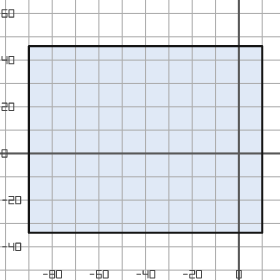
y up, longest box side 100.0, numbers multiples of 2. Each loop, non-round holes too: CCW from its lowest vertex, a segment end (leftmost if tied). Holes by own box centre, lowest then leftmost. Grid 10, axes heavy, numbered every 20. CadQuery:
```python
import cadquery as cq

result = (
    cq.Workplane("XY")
    .moveTo(-90.0, -34.0)
    .lineTo(10.0, -34.0)
    .lineTo(10.0, 46.0)
    .lineTo(-90.0, 46.0)
    .close()
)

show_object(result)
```